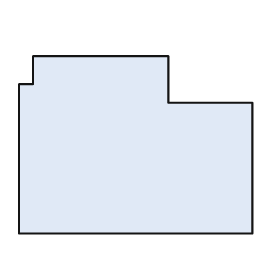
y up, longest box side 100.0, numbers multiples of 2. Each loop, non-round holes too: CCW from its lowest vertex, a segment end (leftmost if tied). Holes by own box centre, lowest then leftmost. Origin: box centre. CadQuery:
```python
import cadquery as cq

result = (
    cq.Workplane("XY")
    .moveTo(-50.0, -38.0)
    .lineTo(50.0, -38.0)
    .lineTo(50.0, 18.0)
    .lineTo(14.0, 18.0)
    .lineTo(14.0, 38.0)
    .lineTo(-44.0, 38.0)
    .lineTo(-44.0, 26.0)
    .lineTo(-50.0, 26.0)
    .close()
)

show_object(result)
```